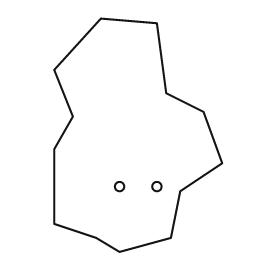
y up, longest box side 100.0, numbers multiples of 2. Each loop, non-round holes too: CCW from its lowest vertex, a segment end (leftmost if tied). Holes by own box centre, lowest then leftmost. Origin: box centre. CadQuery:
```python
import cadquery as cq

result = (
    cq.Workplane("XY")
    .moveTo(-8.0, -50.0)
    .lineTo(14.0, -44.0)
    .lineTo(18.0, -24.0)
    .lineTo(36.0, -12.0)
    .lineTo(28.0, 10.0)
    .lineTo(12.0, 18.0)
    .lineTo(8.0, 48.0)
    .lineTo(-16.0, 50.0)
    .lineTo(-36.0, 28.0)
    .lineTo(-28.0, 8.0)
    .lineTo(-36.0, -6.0)
    .lineTo(-36.0, -38.0)
    .lineTo(-18.0, -44.0)
    .close()
    .moveTo(-8.0, -22.0)
    .circle(2.0)
    .moveTo(8.0, -22.0)
    .circle(2.0)
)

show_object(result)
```